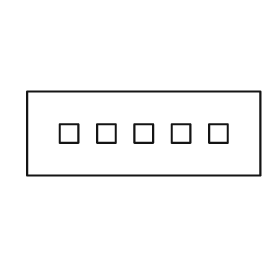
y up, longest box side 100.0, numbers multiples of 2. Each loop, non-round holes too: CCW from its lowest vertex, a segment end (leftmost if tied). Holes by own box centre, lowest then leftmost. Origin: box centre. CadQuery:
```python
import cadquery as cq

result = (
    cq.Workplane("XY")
    .moveTo(-50.0, -18.0)
    .lineTo(50.0, -18.0)
    .lineTo(50.0, 18.0)
    .lineTo(-50.0, 18.0)
    .close()
    .moveTo(-36.0, -4.0)
    .lineTo(-28.0, -4.0)
    .lineTo(-28.0, 4.0)
    .lineTo(-36.0, 4.0)
    .close()
    .moveTo(-20.0, -4.0)
    .lineTo(-12.0, -4.0)
    .lineTo(-12.0, 4.0)
    .lineTo(-20.0, 4.0)
    .close()
    .moveTo(-4.0, -4.0)
    .lineTo(4.0, -4.0)
    .lineTo(4.0, 4.0)
    .lineTo(-4.0, 4.0)
    .close()
    .moveTo(12.0, -4.0)
    .lineTo(20.0, -4.0)
    .lineTo(20.0, 4.0)
    .lineTo(12.0, 4.0)
    .close()
    .moveTo(28.0, -4.0)
    .lineTo(36.0, -4.0)
    .lineTo(36.0, 4.0)
    .lineTo(28.0, 4.0)
    .close()
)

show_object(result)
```